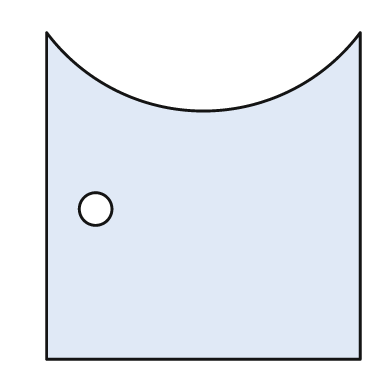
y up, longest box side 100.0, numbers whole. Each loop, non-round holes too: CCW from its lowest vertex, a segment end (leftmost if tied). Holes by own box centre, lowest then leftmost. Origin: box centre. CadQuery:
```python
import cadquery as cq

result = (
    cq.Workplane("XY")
    .moveTo(-48.0, -50.0)
    .lineTo(48.0, -50.0)
    .lineTo(48.0, 50.0)
    .threePointArc((0.0, 26.0), (-48.0, 50.0))
    .close()
    .moveTo(-33.0, -4.0)
    .circle(5.0)
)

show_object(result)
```